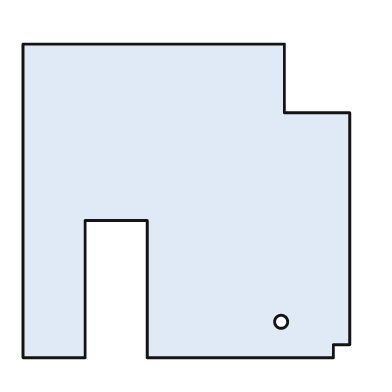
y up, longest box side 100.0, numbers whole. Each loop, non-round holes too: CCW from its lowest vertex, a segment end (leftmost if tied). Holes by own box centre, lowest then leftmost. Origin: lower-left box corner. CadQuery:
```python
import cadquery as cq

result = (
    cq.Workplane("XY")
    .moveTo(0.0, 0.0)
    .lineTo(19.0, 0.0)
    .lineTo(19.0, 42.0)
    .lineTo(38.0, 42.0)
    .lineTo(38.0, 0.0)
    .lineTo(95.0, 0.0)
    .lineTo(95.0, 4.0)
    .lineTo(100.0, 4.0)
    .lineTo(100.0, 75.0)
    .lineTo(80.0, 75.0)
    .lineTo(80.0, 96.0)
    .lineTo(0.0, 96.0)
    .close()
    .moveTo(79.0, 11.0)
    .circle(2.0)
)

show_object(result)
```